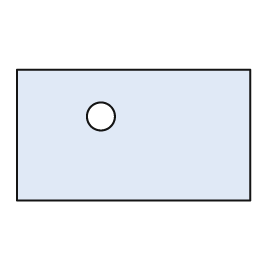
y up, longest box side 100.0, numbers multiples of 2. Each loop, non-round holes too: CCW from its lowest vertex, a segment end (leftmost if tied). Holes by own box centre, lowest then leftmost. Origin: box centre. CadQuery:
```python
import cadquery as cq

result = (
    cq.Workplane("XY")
    .moveTo(-50.0, -28.0)
    .lineTo(50.0, -28.0)
    .lineTo(50.0, 28.0)
    .lineTo(-50.0, 28.0)
    .close()
    .moveTo(-14.0, 8.0)
    .circle(6.0)
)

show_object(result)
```